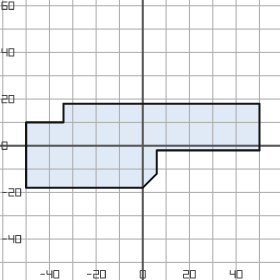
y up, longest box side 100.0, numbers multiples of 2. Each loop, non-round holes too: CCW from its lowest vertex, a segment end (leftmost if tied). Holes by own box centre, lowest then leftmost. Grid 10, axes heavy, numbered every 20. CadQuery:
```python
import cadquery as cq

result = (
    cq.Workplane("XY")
    .moveTo(-50.0, -18.0)
    .lineTo(0.0, -18.0)
    .lineTo(6.0, -12.0)
    .lineTo(6.0, -2.0)
    .lineTo(50.0, -2.0)
    .lineTo(50.0, 18.0)
    .lineTo(-34.0, 18.0)
    .lineTo(-34.0, 10.0)
    .lineTo(-50.0, 10.0)
    .close()
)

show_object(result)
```